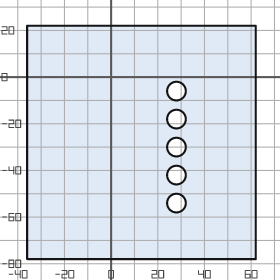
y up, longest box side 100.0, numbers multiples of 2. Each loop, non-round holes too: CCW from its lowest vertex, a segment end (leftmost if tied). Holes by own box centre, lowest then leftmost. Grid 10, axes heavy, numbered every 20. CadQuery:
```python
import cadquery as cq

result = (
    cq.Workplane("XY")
    .moveTo(-36.0, -78.0)
    .lineTo(62.0, -78.0)
    .lineTo(62.0, 22.0)
    .lineTo(-36.0, 22.0)
    .close()
    .moveTo(28.0, -54.0)
    .circle(4.0)
    .moveTo(28.0, -42.0)
    .circle(4.0)
    .moveTo(28.0, -30.0)
    .circle(4.0)
    .moveTo(28.0, -18.0)
    .circle(4.0)
    .moveTo(28.0, -6.0)
    .circle(4.0)
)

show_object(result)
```